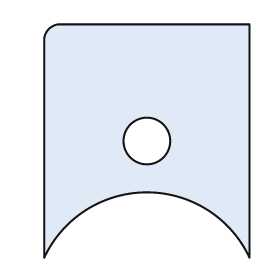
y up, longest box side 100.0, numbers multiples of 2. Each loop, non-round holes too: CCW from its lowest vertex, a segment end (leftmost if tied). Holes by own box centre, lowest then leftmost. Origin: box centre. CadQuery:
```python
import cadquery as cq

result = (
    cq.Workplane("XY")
    .moveTo(-44.0, -50.0)
    .threePointArc((0.0, -22.0), (44.0, -50.0))
    .lineTo(44.0, 50.0)
    .lineTo(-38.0, 50.0)
    .threePointArc((-42.0, 48.0), (-44.0, 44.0))
    .close()
    .moveTo(0.0, 0.0)
    .circle(10.0)
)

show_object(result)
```